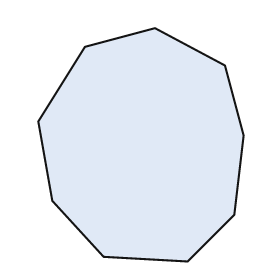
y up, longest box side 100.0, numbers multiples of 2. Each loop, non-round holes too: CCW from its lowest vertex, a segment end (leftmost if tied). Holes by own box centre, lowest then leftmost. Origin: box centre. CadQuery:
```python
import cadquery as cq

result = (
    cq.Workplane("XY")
    .moveTo(20.0, -50.0)
    .lineTo(40.0, -30.0)
    .lineTo(44.0, 4.0)
    .lineTo(36.0, 34.0)
    .lineTo(6.0, 50.0)
    .lineTo(-24.0, 42.0)
    .lineTo(-44.0, 10.0)
    .lineTo(-38.0, -24.0)
    .lineTo(-16.0, -48.0)
    .close()
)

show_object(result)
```